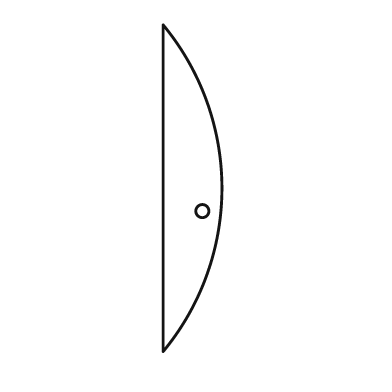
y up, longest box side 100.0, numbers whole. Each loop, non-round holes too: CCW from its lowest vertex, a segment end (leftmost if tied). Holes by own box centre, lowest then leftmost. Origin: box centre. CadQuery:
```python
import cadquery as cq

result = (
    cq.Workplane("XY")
    .moveTo(-9.0, -50.0)
    .threePointArc((9.0, 0.0), (-9.0, 50.0))
    .close()
    .moveTo(3.0, -7.0)
    .circle(2.0)
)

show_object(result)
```